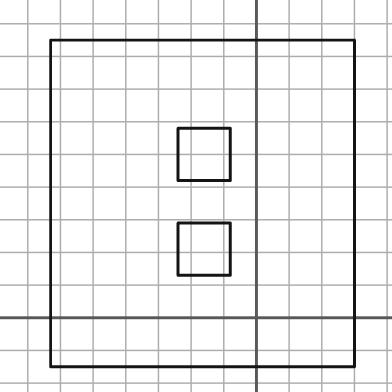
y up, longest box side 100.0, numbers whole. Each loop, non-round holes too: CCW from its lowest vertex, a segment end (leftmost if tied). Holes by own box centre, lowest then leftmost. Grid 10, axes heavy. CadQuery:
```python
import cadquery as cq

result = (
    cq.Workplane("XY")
    .moveTo(-63.0, -15.0)
    .lineTo(30.0, -15.0)
    .lineTo(30.0, 85.0)
    .lineTo(-63.0, 85.0)
    .close()
    .moveTo(-24.0, 13.0)
    .lineTo(-8.0, 13.0)
    .lineTo(-8.0, 29.0)
    .lineTo(-24.0, 29.0)
    .close()
    .moveTo(-24.0, 42.0)
    .lineTo(-8.0, 42.0)
    .lineTo(-8.0, 58.0)
    .lineTo(-24.0, 58.0)
    .close()
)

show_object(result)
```